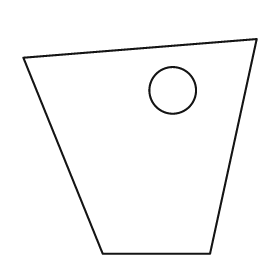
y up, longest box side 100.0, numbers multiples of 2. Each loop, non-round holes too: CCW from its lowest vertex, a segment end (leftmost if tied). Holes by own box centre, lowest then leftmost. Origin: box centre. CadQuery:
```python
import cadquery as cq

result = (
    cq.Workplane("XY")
    .moveTo(-16.0, -46.0)
    .lineTo(30.0, -46.0)
    .lineTo(50.0, 46.0)
    .lineTo(-50.0, 38.0)
    .close()
    .moveTo(14.0, 24.0)
    .circle(10.0)
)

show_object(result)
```